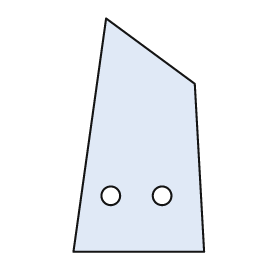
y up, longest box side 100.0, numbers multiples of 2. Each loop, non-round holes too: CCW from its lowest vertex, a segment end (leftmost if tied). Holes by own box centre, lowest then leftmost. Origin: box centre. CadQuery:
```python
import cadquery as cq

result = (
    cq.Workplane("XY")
    .moveTo(-28.0, -50.0)
    .lineTo(28.0, -50.0)
    .lineTo(24.0, 22.0)
    .lineTo(-14.0, 50.0)
    .close()
    .moveTo(-12.0, -26.0)
    .circle(4.0)
    .moveTo(10.0, -26.0)
    .circle(4.0)
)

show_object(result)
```